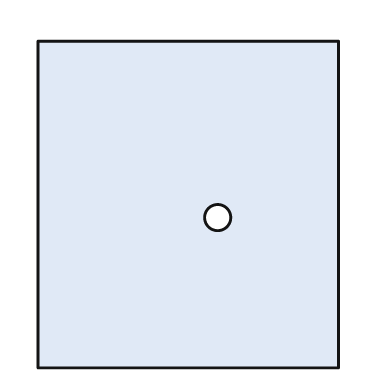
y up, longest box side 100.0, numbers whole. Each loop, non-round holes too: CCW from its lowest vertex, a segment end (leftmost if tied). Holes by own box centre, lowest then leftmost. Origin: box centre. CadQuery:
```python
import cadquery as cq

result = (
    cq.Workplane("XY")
    .moveTo(-46.0, -50.0)
    .lineTo(46.0, -50.0)
    .lineTo(46.0, 50.0)
    .lineTo(-46.0, 50.0)
    .close()
    .moveTo(9.0, -4.0)
    .circle(4.0)
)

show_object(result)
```